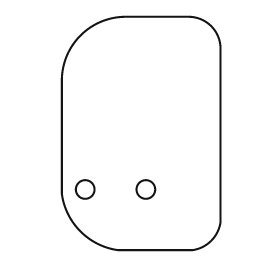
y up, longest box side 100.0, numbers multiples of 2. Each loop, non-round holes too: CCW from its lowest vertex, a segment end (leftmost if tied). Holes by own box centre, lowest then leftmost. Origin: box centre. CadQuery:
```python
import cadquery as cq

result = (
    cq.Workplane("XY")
    .moveTo(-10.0, -50.0)
    .lineTo(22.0, -50.0)
    .threePointArc((30.0, -46.0), (34.0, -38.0))
    .lineTo(34.0, 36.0)
    .threePointArc((30.0, 46.0), (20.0, 50.0))
    .lineTo(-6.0, 50.0)
    .threePointArc((-26.0, 42.0), (-34.0, 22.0))
    .lineTo(-34.0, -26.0)
    .threePointArc((-26.0, -42.0), (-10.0, -50.0))
    .close()
    .moveTo(-24.0, -24.0)
    .circle(4.0)
    .moveTo(2.0, -24.0)
    .circle(4.0)
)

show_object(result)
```